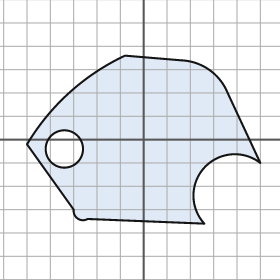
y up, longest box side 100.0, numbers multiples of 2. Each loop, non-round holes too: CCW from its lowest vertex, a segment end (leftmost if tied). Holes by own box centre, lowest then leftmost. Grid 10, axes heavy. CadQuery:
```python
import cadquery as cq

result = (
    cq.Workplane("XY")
    .moveTo(26.0, -36.0)
    .threePointArc((26.0, -12.0), (50.0, -10.0))
    .lineTo(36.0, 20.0)
    .threePointArc((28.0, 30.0), (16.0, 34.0))
    .lineTo(-8.0, 36.0)
    .threePointArc((-32.0, 20.0), (-50.0, -2.0))
    .lineTo(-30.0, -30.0)
    .threePointArc((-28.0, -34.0), (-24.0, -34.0))
    .close()
    .moveTo(-34.0, -4.0)
    .circle(8.0)
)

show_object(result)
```